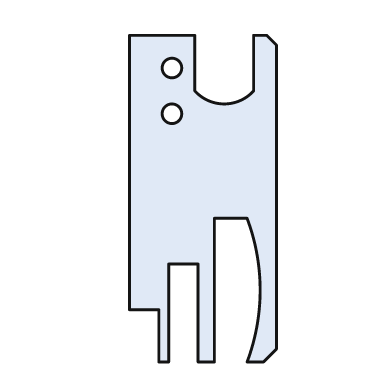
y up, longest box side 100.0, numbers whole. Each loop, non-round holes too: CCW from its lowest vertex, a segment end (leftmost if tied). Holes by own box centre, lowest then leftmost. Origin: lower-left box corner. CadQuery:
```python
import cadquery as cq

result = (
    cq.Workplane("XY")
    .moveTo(9.0, 0.0)
    .lineTo(12.0, 0.0)
    .lineTo(12.0, 30.0)
    .lineTo(21.0, 30.0)
    .lineTo(21.0, 0.0)
    .lineTo(26.0, 0.0)
    .lineTo(26.0, 44.0)
    .lineTo(36.0, 44.0)
    .threePointArc((40.0, 22.0), (36.0, 0.0))
    .lineTo(41.0, 0.0)
    .lineTo(45.0, 4.0)
    .lineTo(45.0, 97.0)
    .lineTo(42.0, 100.0)
    .lineTo(38.0, 100.0)
    .lineTo(38.0, 83.0)
    .threePointArc((29.0, 79.0), (20.0, 83.0))
    .lineTo(20.0, 100.0)
    .lineTo(0.0, 100.0)
    .lineTo(0.0, 16.0)
    .lineTo(9.0, 16.0)
    .close()
    .moveTo(13.0, 76.0)
    .circle(3.0)
    .moveTo(13.0, 90.0)
    .circle(3.0)
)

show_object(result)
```